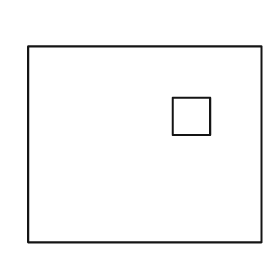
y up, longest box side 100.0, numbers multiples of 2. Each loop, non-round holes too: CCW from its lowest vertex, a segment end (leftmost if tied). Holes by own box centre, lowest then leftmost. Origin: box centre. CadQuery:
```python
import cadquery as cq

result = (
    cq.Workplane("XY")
    .moveTo(-50.0, -42.0)
    .lineTo(50.0, -42.0)
    .lineTo(50.0, 42.0)
    .lineTo(-50.0, 42.0)
    .close()
    .moveTo(12.0, 4.0)
    .lineTo(28.0, 4.0)
    .lineTo(28.0, 20.0)
    .lineTo(12.0, 20.0)
    .close()
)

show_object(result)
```